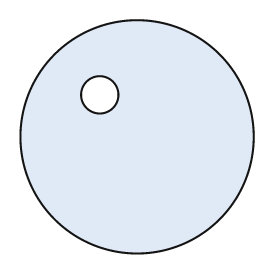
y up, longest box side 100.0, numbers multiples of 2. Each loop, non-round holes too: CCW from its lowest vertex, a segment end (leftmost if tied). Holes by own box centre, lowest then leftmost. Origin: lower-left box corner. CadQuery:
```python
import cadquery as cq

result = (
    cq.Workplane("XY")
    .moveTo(50.0, 50.0)
    .circle(50.0)
    .moveTo(34.0, 68.0)
    .circle(8.0)
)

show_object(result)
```